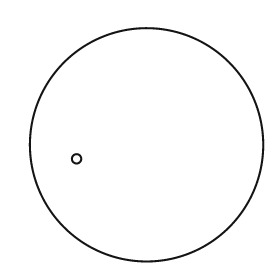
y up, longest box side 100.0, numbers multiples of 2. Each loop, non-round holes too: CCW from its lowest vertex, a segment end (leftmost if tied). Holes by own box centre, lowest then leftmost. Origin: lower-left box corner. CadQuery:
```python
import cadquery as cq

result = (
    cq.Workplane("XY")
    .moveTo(50.0, 50.0)
    .circle(50.0)
    .moveTo(20.0, 44.0)
    .circle(2.0)
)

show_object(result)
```